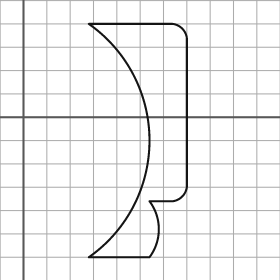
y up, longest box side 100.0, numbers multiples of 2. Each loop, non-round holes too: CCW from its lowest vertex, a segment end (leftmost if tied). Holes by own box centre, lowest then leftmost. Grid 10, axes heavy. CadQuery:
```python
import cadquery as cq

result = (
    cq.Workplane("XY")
    .moveTo(28.0, -60.0)
    .lineTo(54.0, -60.0)
    .threePointArc((58.0, -48.0), (54.0, -36.0))
    .lineTo(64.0, -36.0)
    .threePointArc((68.0, -34.0), (70.0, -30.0))
    .lineTo(70.0, 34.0)
    .threePointArc((68.0, 38.0), (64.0, 40.0))
    .lineTo(28.0, 40.0)
    .threePointArc((54.0, -10.0), (28.0, -60.0))
    .close()
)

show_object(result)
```